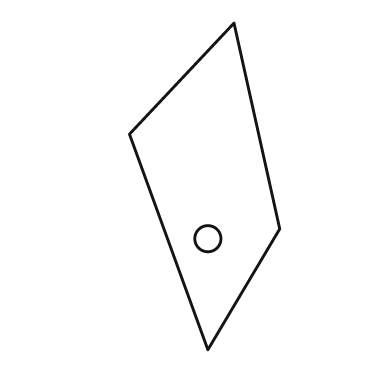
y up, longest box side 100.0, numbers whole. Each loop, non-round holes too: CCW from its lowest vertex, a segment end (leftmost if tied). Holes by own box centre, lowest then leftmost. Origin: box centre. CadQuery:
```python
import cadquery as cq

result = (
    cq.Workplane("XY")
    .moveTo(1.0, -50.0)
    .lineTo(23.0, -13.0)
    .lineTo(9.0, 50.0)
    .lineTo(-23.0, 16.0)
    .close()
    .moveTo(1.0, -16.0)
    .circle(4.0)
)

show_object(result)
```